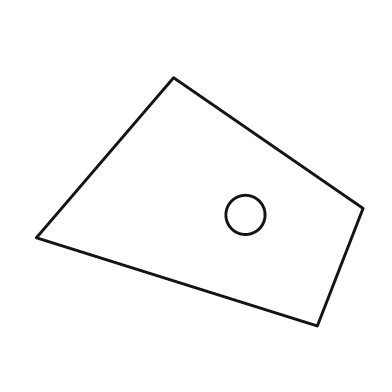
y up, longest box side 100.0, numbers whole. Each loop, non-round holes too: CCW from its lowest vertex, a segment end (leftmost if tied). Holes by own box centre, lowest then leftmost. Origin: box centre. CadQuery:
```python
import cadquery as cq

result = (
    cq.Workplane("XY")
    .moveTo(36.0, -38.0)
    .lineTo(50.0, -2.0)
    .lineTo(-8.0, 38.0)
    .lineTo(-50.0, -11.0)
    .close()
    .moveTo(14.0, -4.0)
    .circle(6.0)
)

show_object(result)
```